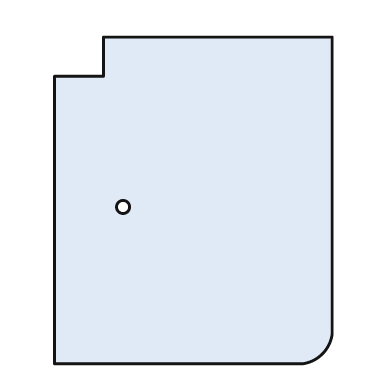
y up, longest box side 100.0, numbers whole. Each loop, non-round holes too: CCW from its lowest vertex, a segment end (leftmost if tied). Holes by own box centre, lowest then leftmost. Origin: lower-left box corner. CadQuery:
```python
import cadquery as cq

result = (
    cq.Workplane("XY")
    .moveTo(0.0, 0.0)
    .lineTo(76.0, 0.0)
    .threePointArc((82.0, 3.0), (85.0, 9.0))
    .lineTo(85.0, 100.0)
    .lineTo(15.0, 100.0)
    .lineTo(15.0, 88.0)
    .lineTo(0.0, 88.0)
    .close()
    .moveTo(21.0, 48.0)
    .circle(2.0)
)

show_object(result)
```